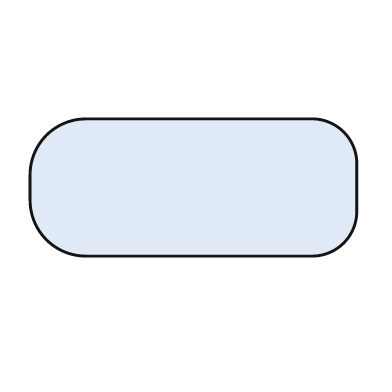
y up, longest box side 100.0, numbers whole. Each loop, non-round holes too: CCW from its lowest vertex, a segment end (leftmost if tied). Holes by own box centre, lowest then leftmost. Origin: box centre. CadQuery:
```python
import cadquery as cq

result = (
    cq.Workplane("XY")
    .moveTo(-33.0, -21.0)
    .lineTo(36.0, -21.0)
    .threePointArc((46.0, -17.0), (50.0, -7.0))
    .lineTo(50.0, 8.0)
    .threePointArc((46.0, 17.0), (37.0, 21.0))
    .lineTo(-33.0, 21.0)
    .threePointArc((-45.0, 16.0), (-50.0, 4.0))
    .lineTo(-50.0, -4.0)
    .threePointArc((-45.0, -16.0), (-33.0, -21.0))
    .close()
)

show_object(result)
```